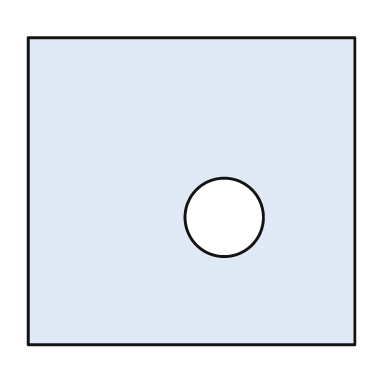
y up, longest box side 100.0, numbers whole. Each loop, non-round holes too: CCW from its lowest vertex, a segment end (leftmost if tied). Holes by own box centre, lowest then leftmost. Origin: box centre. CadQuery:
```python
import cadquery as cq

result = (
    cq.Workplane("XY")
    .moveTo(-50.0, -47.0)
    .lineTo(50.0, -47.0)
    .lineTo(50.0, 47.0)
    .lineTo(-50.0, 47.0)
    .close()
    .moveTo(10.0, -8.0)
    .circle(12.0)
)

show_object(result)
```